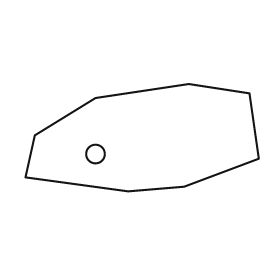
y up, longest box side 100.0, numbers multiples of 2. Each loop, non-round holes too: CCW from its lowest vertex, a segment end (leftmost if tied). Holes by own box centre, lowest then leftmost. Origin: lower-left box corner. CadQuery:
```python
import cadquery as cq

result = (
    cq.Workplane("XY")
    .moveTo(44.0, 0.0)
    .lineTo(68.0, 2.0)
    .lineTo(100.0, 14.0)
    .lineTo(96.0, 42.0)
    .lineTo(70.0, 46.0)
    .lineTo(30.0, 40.0)
    .lineTo(4.0, 24.0)
    .lineTo(0.0, 6.0)
    .close()
    .moveTo(30.0, 16.0)
    .circle(4.0)
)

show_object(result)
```